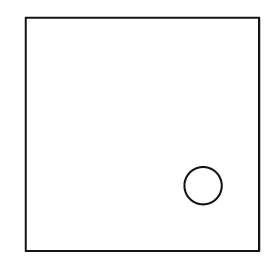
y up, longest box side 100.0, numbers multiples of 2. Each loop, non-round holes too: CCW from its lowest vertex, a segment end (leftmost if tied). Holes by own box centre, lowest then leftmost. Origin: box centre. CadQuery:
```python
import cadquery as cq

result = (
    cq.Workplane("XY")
    .moveTo(-50.0, -50.0)
    .lineTo(50.0, -50.0)
    .lineTo(50.0, 50.0)
    .lineTo(-50.0, 50.0)
    .close()
    .moveTo(26.0, -22.0)
    .circle(8.0)
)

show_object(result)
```